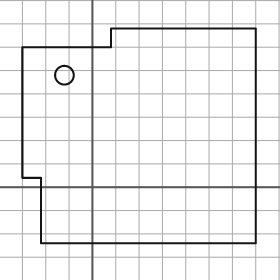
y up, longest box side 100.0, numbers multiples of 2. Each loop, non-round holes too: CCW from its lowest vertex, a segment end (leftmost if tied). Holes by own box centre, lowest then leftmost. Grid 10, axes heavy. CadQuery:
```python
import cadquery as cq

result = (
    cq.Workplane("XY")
    .moveTo(-22.0, -24.0)
    .lineTo(70.0, -24.0)
    .lineTo(70.0, 68.0)
    .lineTo(8.0, 68.0)
    .lineTo(8.0, 60.0)
    .lineTo(-30.0, 60.0)
    .lineTo(-30.0, 4.0)
    .lineTo(-22.0, 4.0)
    .close()
    .moveTo(-12.0, 48.0)
    .circle(4.0)
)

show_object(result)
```